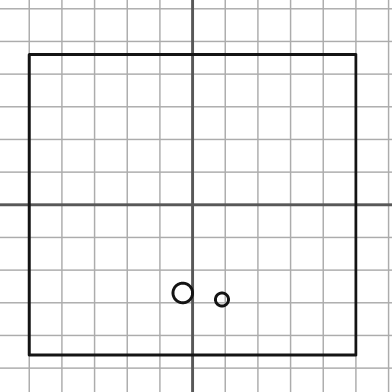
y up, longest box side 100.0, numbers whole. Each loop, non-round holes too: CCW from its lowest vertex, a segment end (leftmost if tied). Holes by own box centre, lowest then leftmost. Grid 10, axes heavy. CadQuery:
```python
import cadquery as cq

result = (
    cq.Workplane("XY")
    .moveTo(-50.0, -46.0)
    .lineTo(50.0, -46.0)
    .lineTo(50.0, 46.0)
    .lineTo(-50.0, 46.0)
    .close()
    .moveTo(9.0, -29.0)
    .circle(2.0)
    .moveTo(-3.0, -27.0)
    .circle(3.0)
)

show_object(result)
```